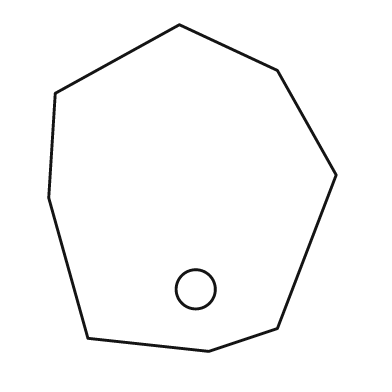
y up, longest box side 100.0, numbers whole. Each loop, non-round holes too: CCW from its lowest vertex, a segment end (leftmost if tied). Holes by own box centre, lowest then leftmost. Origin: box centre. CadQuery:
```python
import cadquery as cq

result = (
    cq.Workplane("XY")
    .moveTo(5.0, -50.0)
    .lineTo(26.0, -43.0)
    .lineTo(44.0, 4.0)
    .lineTo(26.0, 36.0)
    .lineTo(-4.0, 50.0)
    .lineTo(-42.0, 29.0)
    .lineTo(-44.0, -3.0)
    .lineTo(-32.0, -46.0)
    .close()
    .moveTo(1.0, -31.0)
    .circle(6.0)
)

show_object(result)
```